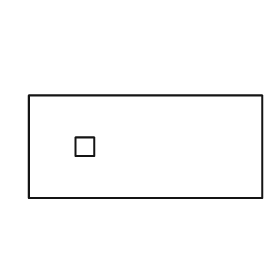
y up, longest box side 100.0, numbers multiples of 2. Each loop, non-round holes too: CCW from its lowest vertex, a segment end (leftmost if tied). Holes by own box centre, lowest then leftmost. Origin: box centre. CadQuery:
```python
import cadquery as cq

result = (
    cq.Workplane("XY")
    .moveTo(-50.0, -22.0)
    .lineTo(50.0, -22.0)
    .lineTo(50.0, 22.0)
    .lineTo(-50.0, 22.0)
    .close()
    .moveTo(-30.0, -4.0)
    .lineTo(-22.0, -4.0)
    .lineTo(-22.0, 4.0)
    .lineTo(-30.0, 4.0)
    .close()
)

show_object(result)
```